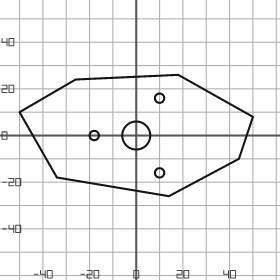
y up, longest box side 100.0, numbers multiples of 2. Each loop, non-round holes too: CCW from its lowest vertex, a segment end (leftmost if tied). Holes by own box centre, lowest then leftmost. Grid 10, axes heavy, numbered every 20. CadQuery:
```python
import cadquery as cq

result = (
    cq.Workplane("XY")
    .moveTo(14.0, -26.0)
    .lineTo(44.0, -10.0)
    .lineTo(50.0, 8.0)
    .lineTo(18.0, 26.0)
    .lineTo(-26.0, 24.0)
    .lineTo(-50.0, 10.0)
    .lineTo(-34.0, -18.0)
    .close()
    .moveTo(10.0, -16.0)
    .circle(2.0)
    .moveTo(-18.0, 0.0)
    .circle(2.0)
    .moveTo(0.0, 0.0)
    .circle(6.0)
    .moveTo(10.0, 16.0)
    .circle(2.0)
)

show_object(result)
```